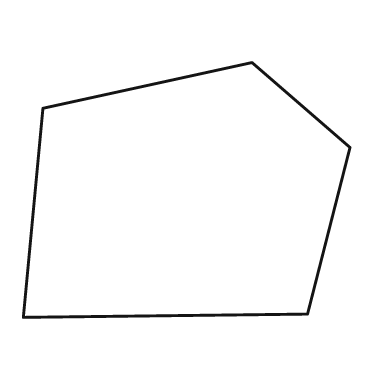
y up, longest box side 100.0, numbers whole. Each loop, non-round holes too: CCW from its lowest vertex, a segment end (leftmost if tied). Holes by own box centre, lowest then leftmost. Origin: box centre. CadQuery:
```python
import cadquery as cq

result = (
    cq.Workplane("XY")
    .moveTo(-50.0, -39.0)
    .lineTo(37.0, -38.0)
    .lineTo(50.0, 13.0)
    .lineTo(20.0, 39.0)
    .lineTo(-44.0, 25.0)
    .close()
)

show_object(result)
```